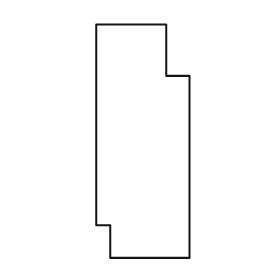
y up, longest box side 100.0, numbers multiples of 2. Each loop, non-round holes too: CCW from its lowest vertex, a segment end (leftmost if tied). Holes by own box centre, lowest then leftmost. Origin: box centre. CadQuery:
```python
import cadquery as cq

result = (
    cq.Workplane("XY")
    .moveTo(-14.0, -50.0)
    .lineTo(20.0, -50.0)
    .lineTo(20.0, 28.0)
    .lineTo(10.0, 28.0)
    .lineTo(10.0, 50.0)
    .lineTo(-20.0, 50.0)
    .lineTo(-20.0, -36.0)
    .lineTo(-14.0, -36.0)
    .close()
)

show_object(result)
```